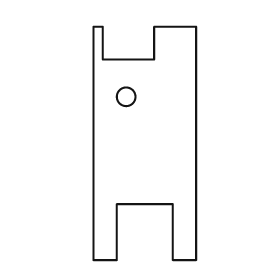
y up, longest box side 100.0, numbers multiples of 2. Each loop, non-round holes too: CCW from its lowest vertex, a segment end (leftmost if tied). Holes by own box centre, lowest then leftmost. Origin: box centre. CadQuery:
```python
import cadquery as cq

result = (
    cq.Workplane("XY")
    .moveTo(-22.0, -50.0)
    .lineTo(-12.0, -50.0)
    .lineTo(-12.0, -26.0)
    .lineTo(12.0, -26.0)
    .lineTo(12.0, -50.0)
    .lineTo(22.0, -50.0)
    .lineTo(22.0, 50.0)
    .lineTo(4.0, 50.0)
    .lineTo(4.0, 36.0)
    .lineTo(-18.0, 36.0)
    .lineTo(-18.0, 50.0)
    .lineTo(-22.0, 50.0)
    .close()
    .moveTo(-8.0, 20.0)
    .circle(4.0)
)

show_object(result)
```